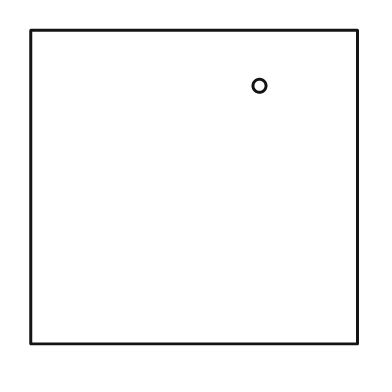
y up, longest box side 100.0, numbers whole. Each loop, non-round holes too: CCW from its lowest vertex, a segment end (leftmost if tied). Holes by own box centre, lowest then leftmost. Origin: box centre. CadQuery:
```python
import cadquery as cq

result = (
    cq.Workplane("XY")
    .moveTo(-50.0, -48.0)
    .lineTo(50.0, -48.0)
    .lineTo(50.0, 48.0)
    .lineTo(-50.0, 48.0)
    .close()
    .moveTo(20.0, 31.0)
    .circle(2.0)
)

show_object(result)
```